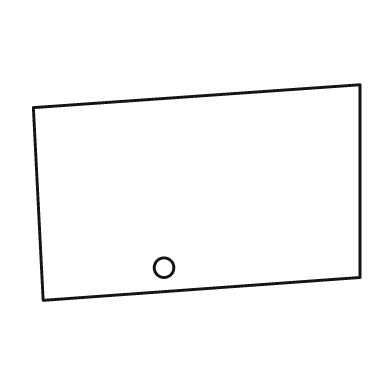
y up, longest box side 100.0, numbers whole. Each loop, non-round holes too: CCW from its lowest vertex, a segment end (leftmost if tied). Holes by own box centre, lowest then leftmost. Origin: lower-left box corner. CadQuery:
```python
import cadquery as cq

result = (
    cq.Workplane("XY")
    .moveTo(3.0, 0.0)
    .lineTo(100.0, 7.0)
    .lineTo(100.0, 66.0)
    .lineTo(0.0, 59.0)
    .close()
    .moveTo(40.0, 10.0)
    .circle(3.0)
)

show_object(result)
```